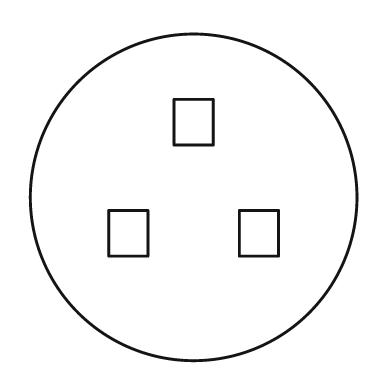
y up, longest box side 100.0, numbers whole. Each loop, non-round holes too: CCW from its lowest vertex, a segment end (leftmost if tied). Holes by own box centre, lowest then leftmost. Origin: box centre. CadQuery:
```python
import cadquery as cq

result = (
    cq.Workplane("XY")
    .moveTo(0.0, 0.0)
    .circle(50.0)
    .moveTo(-26.0, -18.0)
    .lineTo(-14.0, -18.0)
    .lineTo(-14.0, -4.0)
    .lineTo(-26.0, -4.0)
    .close()
    .moveTo(14.0, -18.0)
    .lineTo(26.0, -18.0)
    .lineTo(26.0, -4.0)
    .lineTo(14.0, -4.0)
    .close()
    .moveTo(-6.0, 16.0)
    .lineTo(6.0, 16.0)
    .lineTo(6.0, 30.0)
    .lineTo(-6.0, 30.0)
    .close()
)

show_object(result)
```